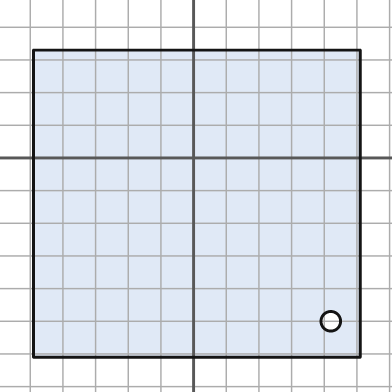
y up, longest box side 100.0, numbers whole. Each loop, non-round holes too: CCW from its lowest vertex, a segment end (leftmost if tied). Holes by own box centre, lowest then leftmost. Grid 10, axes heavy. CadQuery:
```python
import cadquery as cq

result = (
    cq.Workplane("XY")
    .moveTo(-49.0, -61.0)
    .lineTo(51.0, -61.0)
    .lineTo(51.0, 33.0)
    .lineTo(-49.0, 33.0)
    .close()
    .moveTo(42.0, -50.0)
    .circle(3.0)
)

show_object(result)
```